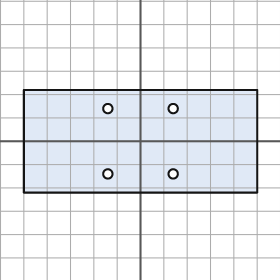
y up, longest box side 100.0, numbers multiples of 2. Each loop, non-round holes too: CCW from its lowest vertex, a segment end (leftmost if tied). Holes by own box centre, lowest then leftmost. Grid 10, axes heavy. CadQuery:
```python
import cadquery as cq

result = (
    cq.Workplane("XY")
    .moveTo(-50.0, -22.0)
    .lineTo(50.0, -22.0)
    .lineTo(50.0, 22.0)
    .lineTo(-50.0, 22.0)
    .close()
    .moveTo(-14.0, -14.0)
    .circle(2.0)
    .moveTo(14.0, -14.0)
    .circle(2.0)
    .moveTo(-14.0, 14.0)
    .circle(2.0)
    .moveTo(14.0, 14.0)
    .circle(2.0)
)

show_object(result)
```